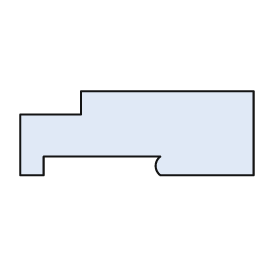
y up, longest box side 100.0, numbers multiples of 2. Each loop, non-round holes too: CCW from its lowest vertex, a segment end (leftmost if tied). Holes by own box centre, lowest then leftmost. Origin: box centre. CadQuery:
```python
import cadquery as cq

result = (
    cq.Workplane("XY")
    .moveTo(-50.0, -18.0)
    .lineTo(-40.0, -18.0)
    .lineTo(-40.0, -10.0)
    .lineTo(10.0, -10.0)
    .threePointArc((8.0, -14.0), (10.0, -18.0))
    .lineTo(50.0, -18.0)
    .lineTo(50.0, 18.0)
    .lineTo(-24.0, 18.0)
    .lineTo(-24.0, 8.0)
    .lineTo(-50.0, 8.0)
    .close()
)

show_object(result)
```